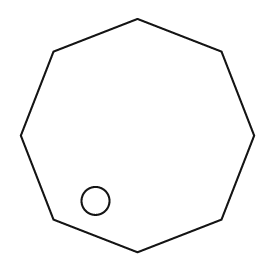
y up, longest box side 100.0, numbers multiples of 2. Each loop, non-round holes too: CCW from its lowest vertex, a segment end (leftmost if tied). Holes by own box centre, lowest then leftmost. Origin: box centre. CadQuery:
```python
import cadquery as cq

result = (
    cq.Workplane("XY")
    .moveTo(0.0, -50.0)
    .lineTo(36.0, -36.0)
    .lineTo(50.0, 0.0)
    .lineTo(36.0, 36.0)
    .lineTo(0.0, 50.0)
    .lineTo(-36.0, 36.0)
    .lineTo(-50.0, 0.0)
    .lineTo(-36.0, -36.0)
    .close()
    .moveTo(-18.0, -28.0)
    .circle(6.0)
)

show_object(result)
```